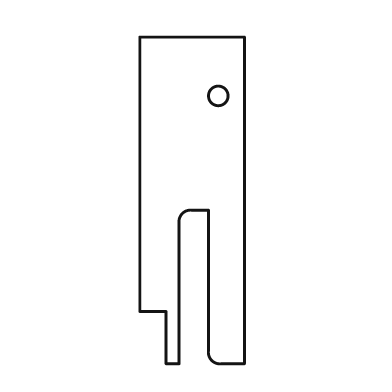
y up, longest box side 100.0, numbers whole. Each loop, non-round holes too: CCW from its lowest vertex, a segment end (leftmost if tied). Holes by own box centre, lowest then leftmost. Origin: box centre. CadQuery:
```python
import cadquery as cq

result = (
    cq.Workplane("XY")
    .moveTo(-8.0, -50.0)
    .lineTo(-4.0, -50.0)
    .lineTo(-4.0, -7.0)
    .threePointArc((-3.0, -4.0), (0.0, -3.0))
    .lineTo(5.0, -3.0)
    .lineTo(5.0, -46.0)
    .threePointArc((6.0, -49.0), (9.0, -50.0))
    .lineTo(16.0, -50.0)
    .lineTo(16.0, 50.0)
    .lineTo(-16.0, 50.0)
    .lineTo(-16.0, -34.0)
    .lineTo(-8.0, -34.0)
    .close()
    .moveTo(8.0, 32.0)
    .circle(3.0)
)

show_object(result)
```